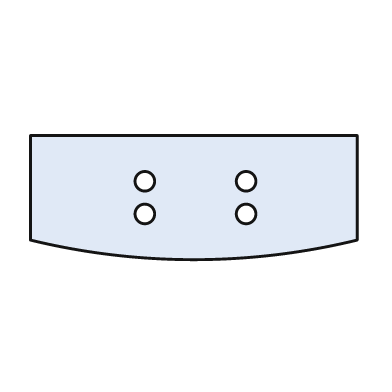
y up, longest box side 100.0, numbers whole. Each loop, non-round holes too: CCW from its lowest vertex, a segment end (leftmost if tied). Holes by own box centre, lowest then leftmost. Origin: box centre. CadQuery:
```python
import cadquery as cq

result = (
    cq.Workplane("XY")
    .moveTo(-50.0, -13.0)
    .threePointArc((0.0, -19.0), (50.0, -13.0))
    .lineTo(50.0, 19.0)
    .lineTo(-50.0, 19.0)
    .close()
    .moveTo(-15.0, -5.0)
    .circle(3.0)
    .moveTo(16.0, -5.0)
    .circle(3.0)
    .moveTo(-15.0, 5.0)
    .circle(3.0)
    .moveTo(16.0, 5.0)
    .circle(3.0)
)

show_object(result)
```